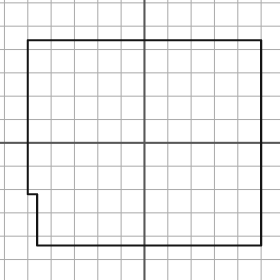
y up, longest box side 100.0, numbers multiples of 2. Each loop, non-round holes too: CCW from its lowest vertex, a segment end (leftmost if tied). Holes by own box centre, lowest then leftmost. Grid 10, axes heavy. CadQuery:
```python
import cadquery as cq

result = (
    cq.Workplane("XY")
    .moveTo(-46.0, -44.0)
    .lineTo(50.0, -44.0)
    .lineTo(50.0, 44.0)
    .lineTo(-50.0, 44.0)
    .lineTo(-50.0, -22.0)
    .lineTo(-46.0, -22.0)
    .close()
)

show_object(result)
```